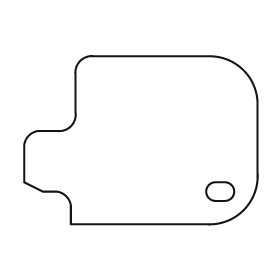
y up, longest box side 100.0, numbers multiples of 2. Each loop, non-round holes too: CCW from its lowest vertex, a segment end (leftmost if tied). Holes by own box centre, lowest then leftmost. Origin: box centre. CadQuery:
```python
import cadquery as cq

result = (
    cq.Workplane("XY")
    .moveTo(-30.0, -36.0)
    .lineTo(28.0, -36.0)
    .threePointArc((44.0, -30.0), (50.0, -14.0))
    .lineTo(50.0, 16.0)
    .threePointArc((44.0, 30.0), (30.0, 36.0))
    .lineTo(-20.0, 36.0)
    .threePointArc((-26.0, 34.0), (-28.0, 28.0))
    .lineTo(-28.0, 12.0)
    .threePointArc((-30.0, 6.0), (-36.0, 4.0))
    .lineTo(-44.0, 4.0)
    .threePointArc((-48.0, 2.0), (-50.0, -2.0))
    .lineTo(-50.0, -18.0)
    .lineTo(-42.0, -22.0)
    .lineTo(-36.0, -22.0)
    .threePointArc((-32.0, -24.0), (-30.0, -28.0))
    .close()
    .moveTo(32.0, -26.0)
    .lineTo(36.0, -26.0)
    .threePointArc((40.0, -22.0), (36.0, -18.0))
    .lineTo(32.0, -18.0)
    .threePointArc((28.0, -22.0), (32.0, -26.0))
    .close()
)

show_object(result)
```